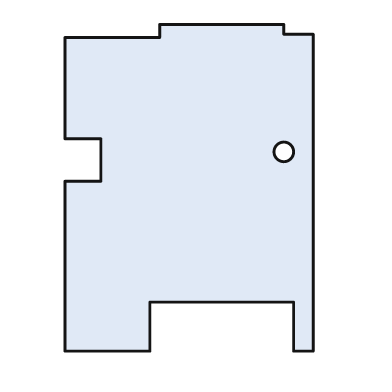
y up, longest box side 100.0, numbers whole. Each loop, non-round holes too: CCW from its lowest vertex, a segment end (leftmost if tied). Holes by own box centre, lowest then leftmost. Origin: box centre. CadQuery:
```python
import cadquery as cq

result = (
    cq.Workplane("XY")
    .moveTo(-38.0, -50.0)
    .lineTo(-12.0, -50.0)
    .lineTo(-12.0, -35.0)
    .lineTo(32.0, -35.0)
    .lineTo(32.0, -50.0)
    .lineTo(38.0, -50.0)
    .lineTo(38.0, 47.0)
    .lineTo(29.0, 47.0)
    .lineTo(29.0, 50.0)
    .lineTo(-9.0, 50.0)
    .lineTo(-9.0, 46.0)
    .lineTo(-38.0, 46.0)
    .lineTo(-38.0, 15.0)
    .lineTo(-27.0, 15.0)
    .lineTo(-27.0, 2.0)
    .lineTo(-38.0, 2.0)
    .close()
    .moveTo(29.0, 11.0)
    .circle(3.0)
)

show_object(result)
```